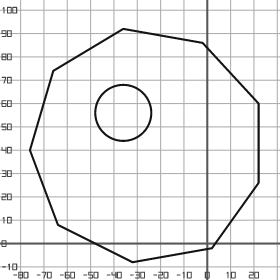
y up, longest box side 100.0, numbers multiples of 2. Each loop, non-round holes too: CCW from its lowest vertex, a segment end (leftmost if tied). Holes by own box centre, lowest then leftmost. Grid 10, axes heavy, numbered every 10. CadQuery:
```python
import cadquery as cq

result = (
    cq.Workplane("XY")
    .moveTo(-32.0, -8.0)
    .lineTo(2.0, -2.0)
    .lineTo(22.0, 26.0)
    .lineTo(22.0, 60.0)
    .lineTo(-2.0, 86.0)
    .lineTo(-36.0, 92.0)
    .lineTo(-66.0, 74.0)
    .lineTo(-76.0, 40.0)
    .lineTo(-64.0, 8.0)
    .close()
    .moveTo(-36.0, 56.0)
    .circle(12.0)
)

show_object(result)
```